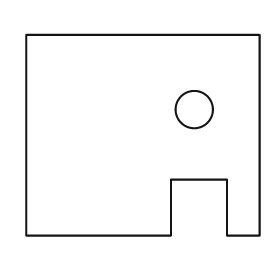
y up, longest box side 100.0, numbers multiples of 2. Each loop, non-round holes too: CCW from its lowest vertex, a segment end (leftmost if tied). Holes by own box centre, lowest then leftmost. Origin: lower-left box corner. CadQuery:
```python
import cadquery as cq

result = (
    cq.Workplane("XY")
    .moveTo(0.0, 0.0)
    .lineTo(62.0, 0.0)
    .lineTo(62.0, 24.0)
    .lineTo(86.0, 24.0)
    .lineTo(86.0, 0.0)
    .lineTo(100.0, 0.0)
    .lineTo(100.0, 86.0)
    .lineTo(0.0, 86.0)
    .close()
    .moveTo(72.0, 54.0)
    .circle(8.0)
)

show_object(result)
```